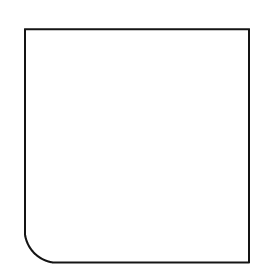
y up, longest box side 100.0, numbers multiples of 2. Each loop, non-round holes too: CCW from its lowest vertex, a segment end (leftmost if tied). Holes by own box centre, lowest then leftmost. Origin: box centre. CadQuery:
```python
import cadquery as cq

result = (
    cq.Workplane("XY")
    .moveTo(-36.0, -50.0)
    .lineTo(48.0, -50.0)
    .lineTo(48.0, 50.0)
    .lineTo(-48.0, 50.0)
    .lineTo(-48.0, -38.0)
    .threePointArc((-44.0, -46.0), (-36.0, -50.0))
    .close()
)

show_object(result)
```